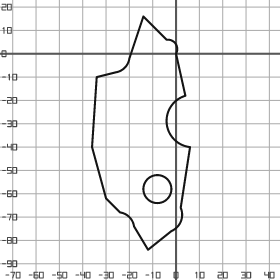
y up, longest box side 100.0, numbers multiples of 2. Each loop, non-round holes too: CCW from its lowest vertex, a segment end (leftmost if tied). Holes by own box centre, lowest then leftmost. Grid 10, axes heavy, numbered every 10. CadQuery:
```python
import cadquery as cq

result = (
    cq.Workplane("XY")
    .moveTo(-12.0, -84.0)
    .lineTo(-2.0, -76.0)
    .threePointArc((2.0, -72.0), (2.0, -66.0))
    .lineTo(6.0, -40.0)
    .threePointArc((-4.0, -30.0), (4.0, -18.0))
    .lineTo(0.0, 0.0)
    .threePointArc((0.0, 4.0), (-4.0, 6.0))
    .lineTo(-14.0, 16.0)
    .lineTo(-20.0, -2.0)
    .threePointArc((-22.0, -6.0), (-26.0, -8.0))
    .lineTo(-34.0, -10.0)
    .lineTo(-36.0, -40.0)
    .lineTo(-30.0, -62.0)
    .lineTo(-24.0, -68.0)
    .threePointArc((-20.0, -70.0), (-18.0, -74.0))
    .close()
    .moveTo(-8.0, -58.0)
    .circle(6.0)
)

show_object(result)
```